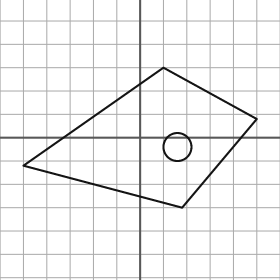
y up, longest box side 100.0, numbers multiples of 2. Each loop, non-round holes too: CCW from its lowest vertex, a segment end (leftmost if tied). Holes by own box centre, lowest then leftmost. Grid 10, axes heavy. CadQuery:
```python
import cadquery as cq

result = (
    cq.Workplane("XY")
    .moveTo(18.0, -30.0)
    .lineTo(50.0, 8.0)
    .lineTo(10.0, 30.0)
    .lineTo(-50.0, -12.0)
    .close()
    .moveTo(16.0, -4.0)
    .circle(6.0)
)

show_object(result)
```